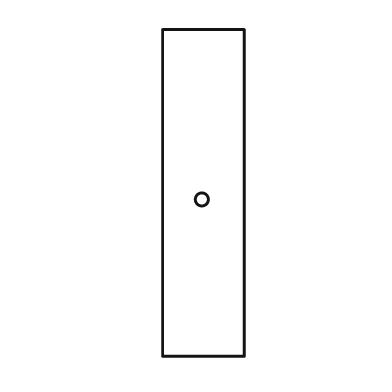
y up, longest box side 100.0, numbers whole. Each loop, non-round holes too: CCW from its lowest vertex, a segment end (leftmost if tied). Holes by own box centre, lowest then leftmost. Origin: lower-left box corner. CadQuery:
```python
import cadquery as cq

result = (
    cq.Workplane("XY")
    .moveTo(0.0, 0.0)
    .lineTo(25.0, 0.0)
    .lineTo(25.0, 100.0)
    .lineTo(0.0, 100.0)
    .close()
    .moveTo(12.0, 48.0)
    .circle(2.0)
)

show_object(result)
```